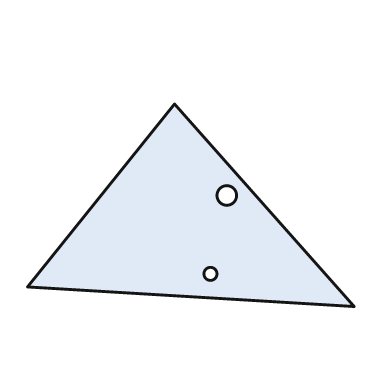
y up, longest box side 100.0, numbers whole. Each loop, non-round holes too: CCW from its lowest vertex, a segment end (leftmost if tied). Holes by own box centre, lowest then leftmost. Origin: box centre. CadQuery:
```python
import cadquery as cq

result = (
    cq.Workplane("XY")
    .moveTo(50.0, -31.0)
    .lineTo(-5.0, 31.0)
    .lineTo(-50.0, -25.0)
    .close()
    .moveTo(6.0, -21.0)
    .circle(2.0)
    .moveTo(11.0, 3.0)
    .circle(3.0)
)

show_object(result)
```